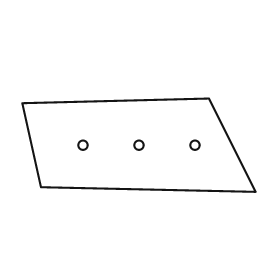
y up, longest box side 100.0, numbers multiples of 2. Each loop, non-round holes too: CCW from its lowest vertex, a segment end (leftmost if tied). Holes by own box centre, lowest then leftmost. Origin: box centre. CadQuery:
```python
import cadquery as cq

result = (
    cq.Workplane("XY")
    .moveTo(50.0, -20.0)
    .lineTo(30.0, 20.0)
    .lineTo(-50.0, 18.0)
    .lineTo(-42.0, -18.0)
    .close()
    .moveTo(-24.0, 0.0)
    .circle(2.0)
    .moveTo(0.0, 0.0)
    .circle(2.0)
    .moveTo(24.0, 0.0)
    .circle(2.0)
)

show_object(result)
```